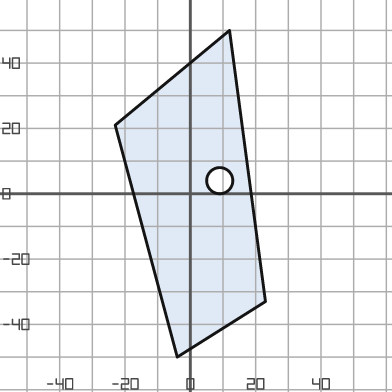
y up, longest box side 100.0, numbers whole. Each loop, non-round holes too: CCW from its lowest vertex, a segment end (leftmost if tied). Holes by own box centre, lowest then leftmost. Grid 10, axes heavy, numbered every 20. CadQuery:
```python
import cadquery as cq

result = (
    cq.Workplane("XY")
    .moveTo(-4.0, -50.0)
    .lineTo(23.0, -33.0)
    .lineTo(12.0, 50.0)
    .lineTo(-23.0, 21.0)
    .close()
    .moveTo(9.0, 4.0)
    .circle(4.0)
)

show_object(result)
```